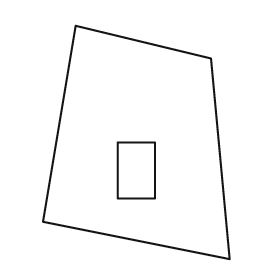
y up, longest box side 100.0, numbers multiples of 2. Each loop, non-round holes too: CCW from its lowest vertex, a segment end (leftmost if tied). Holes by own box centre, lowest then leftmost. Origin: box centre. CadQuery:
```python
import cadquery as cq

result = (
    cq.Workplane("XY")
    .moveTo(40.0, -50.0)
    .lineTo(32.0, 36.0)
    .lineTo(-26.0, 50.0)
    .lineTo(-40.0, -34.0)
    .close()
    .moveTo(-8.0, -24.0)
    .lineTo(8.0, -24.0)
    .lineTo(8.0, 0.0)
    .lineTo(-8.0, 0.0)
    .close()
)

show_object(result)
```